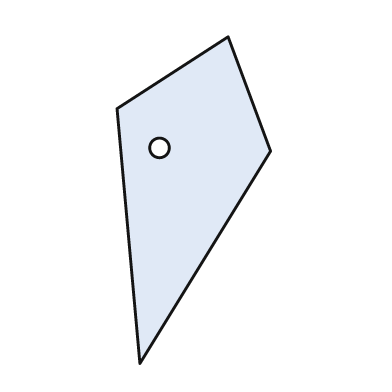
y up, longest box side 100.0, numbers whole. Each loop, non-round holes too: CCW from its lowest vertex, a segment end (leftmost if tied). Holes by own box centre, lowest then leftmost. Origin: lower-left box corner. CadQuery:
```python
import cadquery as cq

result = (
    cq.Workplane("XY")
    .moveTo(7.0, 0.0)
    .lineTo(47.0, 65.0)
    .lineTo(34.0, 100.0)
    .lineTo(0.0, 78.0)
    .close()
    .moveTo(13.0, 66.0)
    .circle(3.0)
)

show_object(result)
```